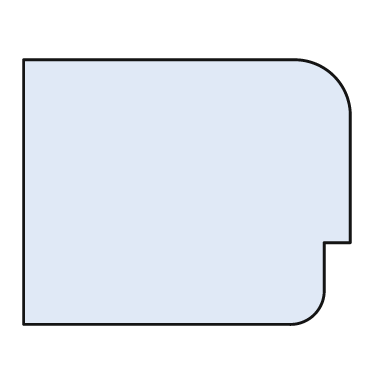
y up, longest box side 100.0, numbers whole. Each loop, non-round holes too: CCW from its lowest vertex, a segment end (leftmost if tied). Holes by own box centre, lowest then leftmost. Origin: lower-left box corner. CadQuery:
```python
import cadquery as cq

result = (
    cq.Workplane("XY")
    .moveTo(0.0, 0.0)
    .lineTo(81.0, 0.0)
    .threePointArc((89.0, 3.0), (92.0, 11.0))
    .lineTo(92.0, 25.0)
    .lineTo(100.0, 25.0)
    .lineTo(100.0, 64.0)
    .threePointArc((95.0, 76.0), (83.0, 81.0))
    .lineTo(0.0, 81.0)
    .close()
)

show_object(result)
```